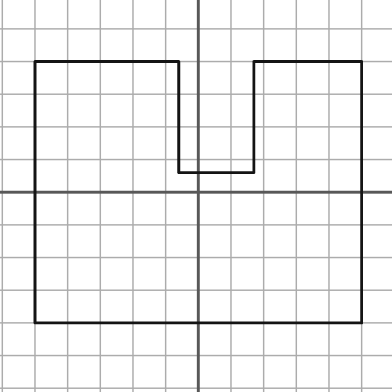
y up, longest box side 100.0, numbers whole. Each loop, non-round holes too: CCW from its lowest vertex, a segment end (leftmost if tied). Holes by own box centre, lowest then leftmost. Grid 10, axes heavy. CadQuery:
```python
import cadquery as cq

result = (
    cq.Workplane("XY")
    .moveTo(-50.0, -40.0)
    .lineTo(50.0, -40.0)
    .lineTo(50.0, 40.0)
    .lineTo(17.0, 40.0)
    .lineTo(17.0, 6.0)
    .lineTo(-6.0, 6.0)
    .lineTo(-6.0, 40.0)
    .lineTo(-50.0, 40.0)
    .close()
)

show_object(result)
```